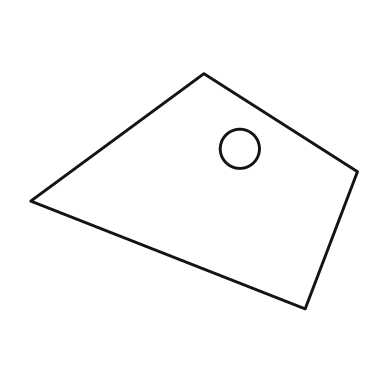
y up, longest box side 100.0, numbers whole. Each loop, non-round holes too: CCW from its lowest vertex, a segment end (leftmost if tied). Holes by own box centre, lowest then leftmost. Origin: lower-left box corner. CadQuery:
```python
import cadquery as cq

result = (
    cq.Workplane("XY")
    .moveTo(84.0, 0.0)
    .lineTo(100.0, 42.0)
    .lineTo(53.0, 72.0)
    .lineTo(0.0, 33.0)
    .close()
    .moveTo(64.0, 49.0)
    .circle(6.0)
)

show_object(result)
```